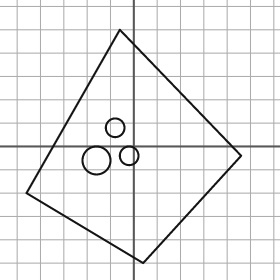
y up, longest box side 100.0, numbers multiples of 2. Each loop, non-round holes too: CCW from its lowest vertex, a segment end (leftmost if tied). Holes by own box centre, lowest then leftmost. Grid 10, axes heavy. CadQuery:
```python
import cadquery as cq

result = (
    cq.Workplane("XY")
    .moveTo(4.0, -50.0)
    .lineTo(46.0, -4.0)
    .lineTo(-6.0, 50.0)
    .lineTo(-46.0, -20.0)
    .close()
    .moveTo(-16.0, -6.0)
    .circle(6.0)
    .moveTo(-2.0, -4.0)
    .circle(4.0)
    .moveTo(-8.0, 8.0)
    .circle(4.0)
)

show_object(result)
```